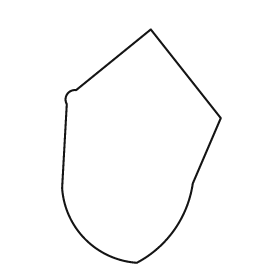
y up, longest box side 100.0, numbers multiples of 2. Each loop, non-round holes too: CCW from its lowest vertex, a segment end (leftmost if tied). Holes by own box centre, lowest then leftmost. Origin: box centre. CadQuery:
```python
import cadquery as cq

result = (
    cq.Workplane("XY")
    .moveTo(-2.0, -50.0)
    .threePointArc((14.0, -36.0), (22.0, -16.0))
    .lineTo(34.0, 12.0)
    .lineTo(4.0, 50.0)
    .lineTo(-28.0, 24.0)
    .threePointArc((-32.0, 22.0), (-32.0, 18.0))
    .lineTo(-34.0, -18.0)
    .threePointArc((-24.0, -40.0), (-2.0, -50.0))
    .close()
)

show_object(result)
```